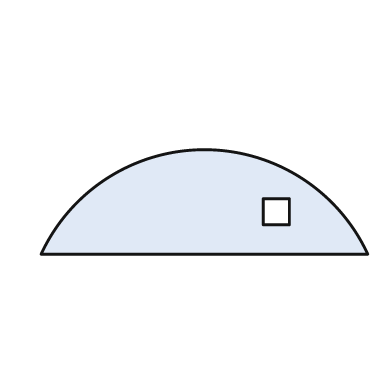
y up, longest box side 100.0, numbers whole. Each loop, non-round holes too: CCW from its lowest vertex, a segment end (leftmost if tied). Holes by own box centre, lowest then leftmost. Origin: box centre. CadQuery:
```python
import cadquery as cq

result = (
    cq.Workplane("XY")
    .moveTo(-50.0, -16.0)
    .lineTo(50.0, -16.0)
    .threePointArc((0.0, 16.0), (-50.0, -16.0))
    .close()
    .moveTo(18.0, -7.0)
    .lineTo(26.0, -7.0)
    .lineTo(26.0, 1.0)
    .lineTo(18.0, 1.0)
    .close()
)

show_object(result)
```